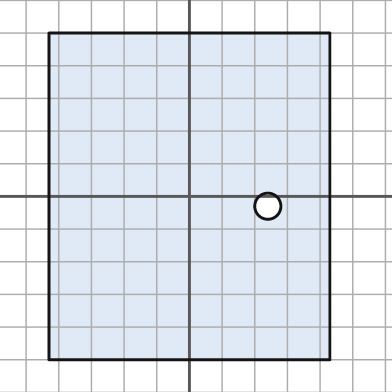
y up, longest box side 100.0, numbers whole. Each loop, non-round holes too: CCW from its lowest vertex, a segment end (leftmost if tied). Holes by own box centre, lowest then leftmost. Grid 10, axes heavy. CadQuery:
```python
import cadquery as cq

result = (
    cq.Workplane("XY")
    .moveTo(-43.0, -50.0)
    .lineTo(43.0, -50.0)
    .lineTo(43.0, 50.0)
    .lineTo(-43.0, 50.0)
    .close()
    .moveTo(24.0, -3.0)
    .circle(4.0)
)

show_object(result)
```